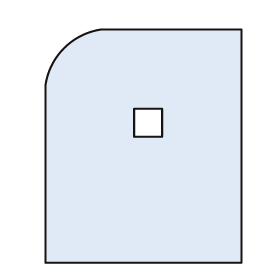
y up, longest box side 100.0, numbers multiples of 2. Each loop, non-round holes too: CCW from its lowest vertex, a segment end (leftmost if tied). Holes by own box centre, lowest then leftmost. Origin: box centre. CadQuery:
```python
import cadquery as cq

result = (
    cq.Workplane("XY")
    .moveTo(-42.0, -50.0)
    .lineTo(42.0, -50.0)
    .lineTo(42.0, 50.0)
    .lineTo(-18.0, 50.0)
    .threePointArc((-34.0, 42.0), (-42.0, 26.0))
    .close()
    .moveTo(-4.0, 4.0)
    .lineTo(8.0, 4.0)
    .lineTo(8.0, 16.0)
    .lineTo(-4.0, 16.0)
    .close()
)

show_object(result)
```